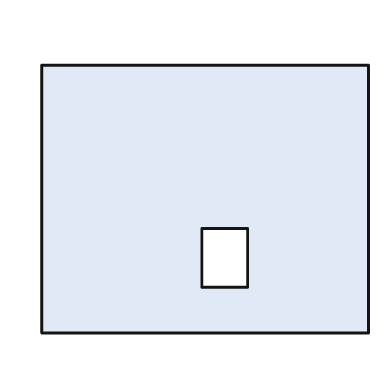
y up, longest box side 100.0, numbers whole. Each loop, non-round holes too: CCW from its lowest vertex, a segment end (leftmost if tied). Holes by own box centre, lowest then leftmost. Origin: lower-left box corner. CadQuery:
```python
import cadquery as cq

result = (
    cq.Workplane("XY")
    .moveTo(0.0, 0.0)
    .lineTo(100.0, 0.0)
    .lineTo(100.0, 82.0)
    .lineTo(0.0, 82.0)
    .close()
    .moveTo(49.0, 14.0)
    .lineTo(63.0, 14.0)
    .lineTo(63.0, 32.0)
    .lineTo(49.0, 32.0)
    .close()
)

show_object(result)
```